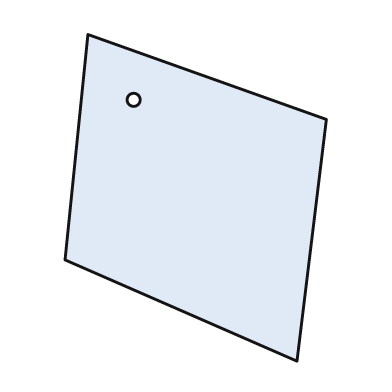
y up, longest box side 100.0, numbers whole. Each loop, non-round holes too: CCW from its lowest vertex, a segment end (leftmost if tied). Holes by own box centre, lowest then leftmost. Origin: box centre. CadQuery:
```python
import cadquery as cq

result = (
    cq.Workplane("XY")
    .moveTo(31.0, -50.0)
    .lineTo(40.0, 24.0)
    .lineTo(-33.0, 50.0)
    .lineTo(-40.0, -19.0)
    .close()
    .moveTo(-19.0, 30.0)
    .circle(2.0)
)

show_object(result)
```